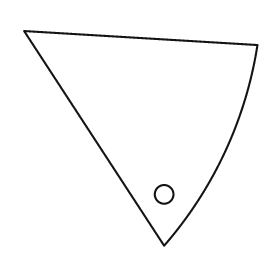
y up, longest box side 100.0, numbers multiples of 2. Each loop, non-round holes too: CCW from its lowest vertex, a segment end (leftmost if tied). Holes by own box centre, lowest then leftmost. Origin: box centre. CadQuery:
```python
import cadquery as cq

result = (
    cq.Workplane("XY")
    .moveTo(10.0, -46.0)
    .threePointArc((36.0, -6.0), (50.0, 40.0))
    .lineTo(-50.0, 46.0)
    .close()
    .moveTo(10.0, -24.0)
    .circle(4.0)
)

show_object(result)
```